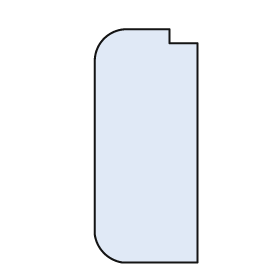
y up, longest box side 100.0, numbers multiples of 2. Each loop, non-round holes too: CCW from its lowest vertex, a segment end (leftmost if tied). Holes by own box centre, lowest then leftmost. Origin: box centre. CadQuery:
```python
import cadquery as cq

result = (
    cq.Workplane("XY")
    .moveTo(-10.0, -50.0)
    .lineTo(22.0, -50.0)
    .lineTo(22.0, 44.0)
    .lineTo(10.0, 44.0)
    .lineTo(10.0, 50.0)
    .lineTo(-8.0, 50.0)
    .threePointArc((-18.0, 46.0), (-22.0, 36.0))
    .lineTo(-22.0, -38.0)
    .threePointArc((-18.0, -46.0), (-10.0, -50.0))
    .close()
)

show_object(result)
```